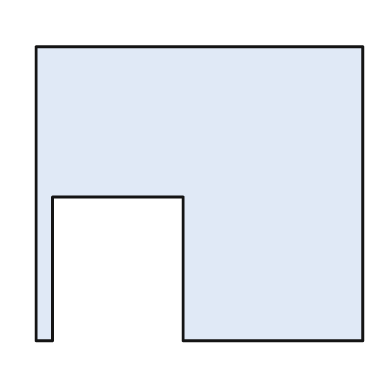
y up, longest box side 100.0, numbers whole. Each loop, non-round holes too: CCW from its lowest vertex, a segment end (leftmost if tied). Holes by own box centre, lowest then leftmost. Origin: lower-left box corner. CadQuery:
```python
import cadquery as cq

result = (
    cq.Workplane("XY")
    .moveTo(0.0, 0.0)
    .lineTo(5.0, 0.0)
    .lineTo(5.0, 44.0)
    .lineTo(45.0, 44.0)
    .lineTo(45.0, 0.0)
    .lineTo(100.0, 0.0)
    .lineTo(100.0, 90.0)
    .lineTo(0.0, 90.0)
    .close()
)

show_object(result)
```